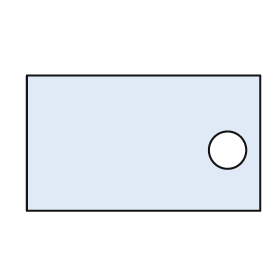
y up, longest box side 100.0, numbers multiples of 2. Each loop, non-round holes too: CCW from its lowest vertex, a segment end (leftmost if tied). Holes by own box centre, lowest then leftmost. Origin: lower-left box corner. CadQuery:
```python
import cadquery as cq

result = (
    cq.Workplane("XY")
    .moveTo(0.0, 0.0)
    .lineTo(100.0, 0.0)
    .lineTo(100.0, 58.0)
    .lineTo(0.0, 58.0)
    .close()
    .moveTo(86.0, 26.0)
    .circle(8.0)
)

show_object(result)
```